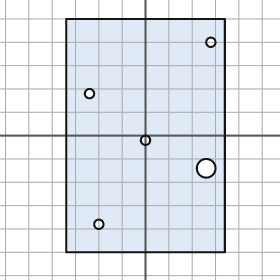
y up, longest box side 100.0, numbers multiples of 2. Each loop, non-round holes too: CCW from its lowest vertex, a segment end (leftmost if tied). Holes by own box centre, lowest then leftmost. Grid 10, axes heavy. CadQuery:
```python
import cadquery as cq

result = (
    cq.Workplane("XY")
    .moveTo(-34.0, -50.0)
    .lineTo(34.0, -50.0)
    .lineTo(34.0, 50.0)
    .lineTo(-34.0, 50.0)
    .close()
    .moveTo(-20.0, -38.0)
    .circle(2.0)
    .moveTo(26.0, -14.0)
    .circle(4.0)
    .moveTo(0.0, -2.0)
    .circle(2.0)
    .moveTo(-24.0, 18.0)
    .circle(2.0)
    .moveTo(28.0, 40.0)
    .circle(2.0)
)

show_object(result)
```